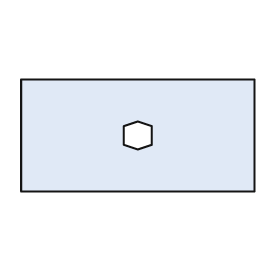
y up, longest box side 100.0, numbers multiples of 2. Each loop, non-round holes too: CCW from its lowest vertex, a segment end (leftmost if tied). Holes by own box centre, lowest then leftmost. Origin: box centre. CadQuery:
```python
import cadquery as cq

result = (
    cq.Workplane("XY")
    .moveTo(-50.0, -24.0)
    .lineTo(50.0, -24.0)
    .lineTo(50.0, 24.0)
    .lineTo(-50.0, 24.0)
    .close()
    .moveTo(0.0, -6.0)
    .lineTo(6.0, -4.0)
    .lineTo(6.0, 4.0)
    .lineTo(0.0, 6.0)
    .lineTo(-6.0, 4.0)
    .lineTo(-6.0, -4.0)
    .close()
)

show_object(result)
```